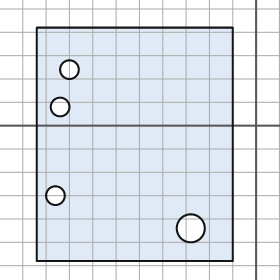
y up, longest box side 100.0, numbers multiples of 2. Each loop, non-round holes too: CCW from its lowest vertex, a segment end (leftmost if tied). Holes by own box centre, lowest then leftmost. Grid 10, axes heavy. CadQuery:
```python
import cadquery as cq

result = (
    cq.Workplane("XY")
    .moveTo(-94.0, -58.0)
    .lineTo(-10.0, -58.0)
    .lineTo(-10.0, 42.0)
    .lineTo(-94.0, 42.0)
    .close()
    .moveTo(-28.0, -44.0)
    .circle(6.0)
    .moveTo(-86.0, -30.0)
    .circle(4.0)
    .moveTo(-84.0, 8.0)
    .circle(4.0)
    .moveTo(-80.0, 24.0)
    .circle(4.0)
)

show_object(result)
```